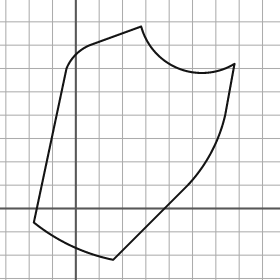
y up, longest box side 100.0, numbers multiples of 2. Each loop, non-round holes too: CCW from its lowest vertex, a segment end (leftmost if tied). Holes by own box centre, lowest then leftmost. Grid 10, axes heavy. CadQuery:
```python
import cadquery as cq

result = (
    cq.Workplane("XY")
    .moveTo(16.0, -22.0)
    .lineTo(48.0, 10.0)
    .threePointArc((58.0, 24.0), (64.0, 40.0))
    .lineTo(68.0, 62.0)
    .threePointArc((44.0, 60.0), (28.0, 78.0))
    .lineTo(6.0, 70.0)
    .threePointArc((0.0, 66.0), (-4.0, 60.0))
    .lineTo(-18.0, -6.0)
    .threePointArc((-2.0, -16.0), (16.0, -22.0))
    .close()
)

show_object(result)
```